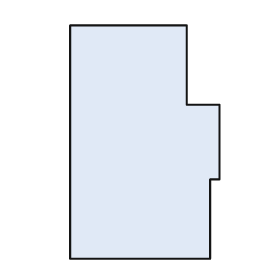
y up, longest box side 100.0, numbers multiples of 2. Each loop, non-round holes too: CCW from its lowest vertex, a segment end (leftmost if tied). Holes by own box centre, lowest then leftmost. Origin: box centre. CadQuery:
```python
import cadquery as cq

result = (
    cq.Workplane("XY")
    .moveTo(-32.0, -50.0)
    .lineTo(28.0, -50.0)
    .lineTo(28.0, -16.0)
    .lineTo(32.0, -16.0)
    .lineTo(32.0, 16.0)
    .lineTo(18.0, 16.0)
    .lineTo(18.0, 50.0)
    .lineTo(-32.0, 50.0)
    .close()
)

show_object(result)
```